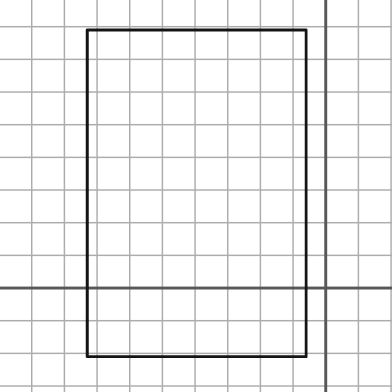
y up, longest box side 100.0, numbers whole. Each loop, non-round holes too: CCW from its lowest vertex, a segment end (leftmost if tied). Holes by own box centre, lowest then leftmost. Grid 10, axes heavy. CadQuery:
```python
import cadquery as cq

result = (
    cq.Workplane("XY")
    .moveTo(-73.0, -21.0)
    .lineTo(-6.0, -21.0)
    .lineTo(-6.0, 79.0)
    .lineTo(-73.0, 79.0)
    .close()
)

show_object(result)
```